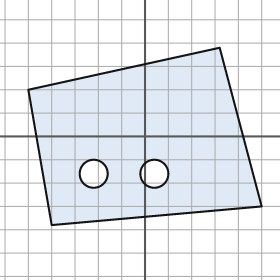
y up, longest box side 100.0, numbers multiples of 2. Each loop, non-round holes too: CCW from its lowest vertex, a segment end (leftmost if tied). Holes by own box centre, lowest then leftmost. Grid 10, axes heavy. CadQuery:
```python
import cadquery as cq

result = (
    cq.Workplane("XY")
    .moveTo(-40.0, -38.0)
    .lineTo(50.0, -30.0)
    .lineTo(32.0, 38.0)
    .lineTo(-50.0, 20.0)
    .close()
    .moveTo(-22.0, -16.0)
    .circle(6.0)
    .moveTo(4.0, -16.0)
    .circle(6.0)
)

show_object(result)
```